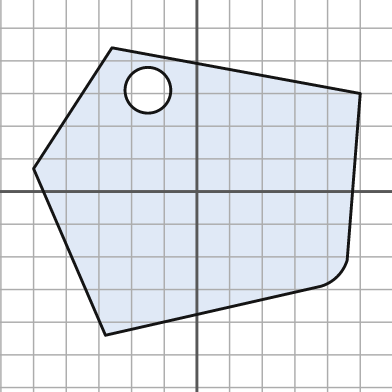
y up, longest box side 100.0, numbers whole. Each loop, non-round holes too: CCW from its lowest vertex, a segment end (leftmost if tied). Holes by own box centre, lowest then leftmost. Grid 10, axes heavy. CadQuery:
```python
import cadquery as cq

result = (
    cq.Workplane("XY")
    .moveTo(-28.0, -44.0)
    .lineTo(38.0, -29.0)
    .threePointArc((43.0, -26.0), (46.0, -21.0))
    .lineTo(50.0, 30.0)
    .lineTo(-26.0, 44.0)
    .lineTo(-50.0, 7.0)
    .close()
    .moveTo(-15.0, 31.0)
    .circle(7.0)
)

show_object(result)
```